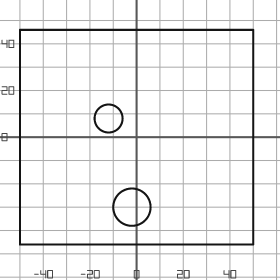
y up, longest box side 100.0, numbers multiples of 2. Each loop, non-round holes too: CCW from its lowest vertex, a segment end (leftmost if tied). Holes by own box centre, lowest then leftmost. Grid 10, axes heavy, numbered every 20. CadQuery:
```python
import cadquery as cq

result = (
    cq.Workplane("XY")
    .moveTo(-50.0, -46.0)
    .lineTo(50.0, -46.0)
    .lineTo(50.0, 46.0)
    .lineTo(-50.0, 46.0)
    .close()
    .moveTo(-2.0, -30.0)
    .circle(8.0)
    .moveTo(-12.0, 8.0)
    .circle(6.0)
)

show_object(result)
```